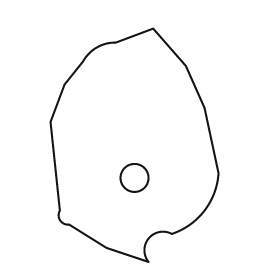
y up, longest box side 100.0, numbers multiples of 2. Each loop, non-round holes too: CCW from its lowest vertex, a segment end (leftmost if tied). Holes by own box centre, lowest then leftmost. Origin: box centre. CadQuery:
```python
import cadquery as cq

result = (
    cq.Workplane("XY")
    .moveTo(6.0, -50.0)
    .threePointArc((6.0, -40.0), (16.0, -38.0))
    .threePointArc((30.0, -28.0), (36.0, -12.0))
    .lineTo(30.0, 16.0)
    .lineTo(22.0, 34.0)
    .lineTo(8.0, 50.0)
    .lineTo(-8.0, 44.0)
    .threePointArc((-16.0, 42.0), (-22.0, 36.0))
    .lineTo(-30.0, 26.0)
    .lineTo(-36.0, 10.0)
    .lineTo(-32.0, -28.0)
    .threePointArc((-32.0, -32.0), (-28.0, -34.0))
    .lineTo(-12.0, -44.0)
    .close()
    .moveTo(0.0, -14.0)
    .circle(6.0)
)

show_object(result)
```